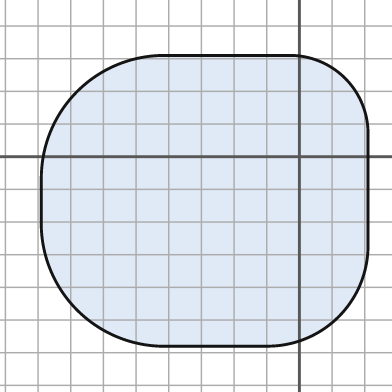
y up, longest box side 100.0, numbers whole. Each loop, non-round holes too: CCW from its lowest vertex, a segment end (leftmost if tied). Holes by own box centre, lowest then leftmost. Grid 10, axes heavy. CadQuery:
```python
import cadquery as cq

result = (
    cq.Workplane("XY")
    .moveTo(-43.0, -58.0)
    .lineTo(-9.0, -58.0)
    .threePointArc((12.0, -49.0), (21.0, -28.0))
    .lineTo(21.0, 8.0)
    .threePointArc((14.0, 24.0), (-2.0, 31.0))
    .lineTo(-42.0, 31.0)
    .threePointArc((-68.0, 20.0), (-79.0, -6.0))
    .lineTo(-79.0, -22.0)
    .threePointArc((-68.0, -47.0), (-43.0, -58.0))
    .close()
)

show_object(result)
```